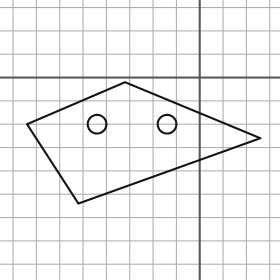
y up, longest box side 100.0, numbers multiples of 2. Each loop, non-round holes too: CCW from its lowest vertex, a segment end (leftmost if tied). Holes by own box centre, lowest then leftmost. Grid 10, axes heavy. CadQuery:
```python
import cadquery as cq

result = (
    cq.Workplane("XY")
    .moveTo(-52.0, -54.0)
    .lineTo(26.0, -26.0)
    .lineTo(-32.0, -2.0)
    .lineTo(-74.0, -20.0)
    .close()
    .moveTo(-44.0, -20.0)
    .circle(4.0)
    .moveTo(-14.0, -20.0)
    .circle(4.0)
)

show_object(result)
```